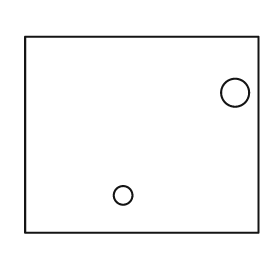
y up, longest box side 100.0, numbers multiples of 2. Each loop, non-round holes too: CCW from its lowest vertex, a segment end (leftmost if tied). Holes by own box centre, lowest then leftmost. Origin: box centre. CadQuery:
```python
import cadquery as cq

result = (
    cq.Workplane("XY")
    .moveTo(-50.0, -42.0)
    .lineTo(50.0, -42.0)
    .lineTo(50.0, 42.0)
    .lineTo(-50.0, 42.0)
    .close()
    .moveTo(-8.0, -26.0)
    .circle(4.0)
    .moveTo(40.0, 18.0)
    .circle(6.0)
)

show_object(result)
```